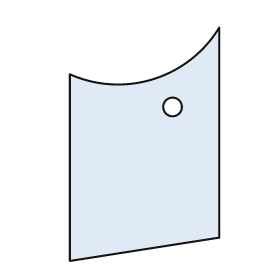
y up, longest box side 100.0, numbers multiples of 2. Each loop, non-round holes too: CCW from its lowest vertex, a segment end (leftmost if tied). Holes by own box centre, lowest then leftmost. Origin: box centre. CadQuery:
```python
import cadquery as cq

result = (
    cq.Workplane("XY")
    .moveTo(-32.0, -50.0)
    .lineTo(32.0, -40.0)
    .lineTo(32.0, 50.0)
    .threePointArc((4.0, 28.0), (-32.0, 30.0))
    .close()
    .moveTo(12.0, 16.0)
    .circle(4.0)
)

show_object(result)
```